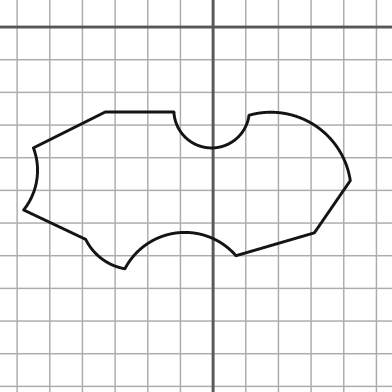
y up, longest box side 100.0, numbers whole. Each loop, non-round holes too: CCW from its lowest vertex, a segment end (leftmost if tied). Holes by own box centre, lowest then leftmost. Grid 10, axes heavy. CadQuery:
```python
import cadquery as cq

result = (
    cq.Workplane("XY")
    .moveTo(-27.0, -74.0)
    .threePointArc((-11.0, -63.0), (7.0, -70.0))
    .lineTo(31.0, -63.0)
    .lineTo(42.0, -47.0)
    .threePointArc((31.0, -30.0), (11.0, -27.0))
    .threePointArc((-1.0, -37.0), (-12.0, -26.0))
    .lineTo(-33.0, -26.0)
    .lineTo(-55.0, -37.0)
    .threePointArc((-54.0, -47.0), (-58.0, -56.0))
    .lineTo(-39.0, -65.0)
    .threePointArc((-34.0, -71.0), (-27.0, -74.0))
    .close()
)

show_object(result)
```